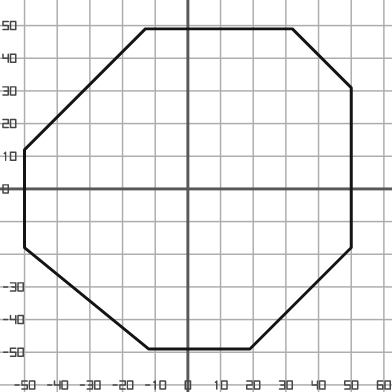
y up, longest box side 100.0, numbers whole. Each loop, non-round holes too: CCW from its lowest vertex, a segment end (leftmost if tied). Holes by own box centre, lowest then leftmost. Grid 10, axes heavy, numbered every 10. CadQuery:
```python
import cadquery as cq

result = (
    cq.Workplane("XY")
    .moveTo(-12.0, -49.0)
    .lineTo(19.0, -49.0)
    .lineTo(50.0, -18.0)
    .lineTo(50.0, 31.0)
    .lineTo(32.0, 49.0)
    .lineTo(-13.0, 49.0)
    .lineTo(-50.0, 12.0)
    .lineTo(-50.0, -18.0)
    .close()
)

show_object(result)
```